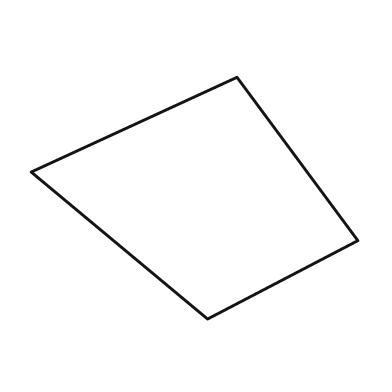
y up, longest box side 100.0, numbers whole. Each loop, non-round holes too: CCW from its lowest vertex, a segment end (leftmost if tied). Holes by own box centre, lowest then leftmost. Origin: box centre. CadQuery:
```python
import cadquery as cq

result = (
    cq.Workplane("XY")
    .moveTo(4.0, -37.0)
    .lineTo(50.0, -13.0)
    .lineTo(13.0, 37.0)
    .lineTo(-50.0, 8.0)
    .close()
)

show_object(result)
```